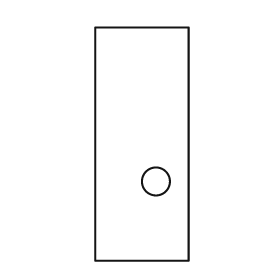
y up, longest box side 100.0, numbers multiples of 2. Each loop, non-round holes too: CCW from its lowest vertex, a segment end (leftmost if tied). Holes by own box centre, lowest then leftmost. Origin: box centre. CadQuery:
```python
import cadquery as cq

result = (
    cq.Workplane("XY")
    .moveTo(-20.0, -50.0)
    .lineTo(20.0, -50.0)
    .lineTo(20.0, 50.0)
    .lineTo(-20.0, 50.0)
    .close()
    .moveTo(6.0, -16.0)
    .circle(6.0)
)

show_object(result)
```